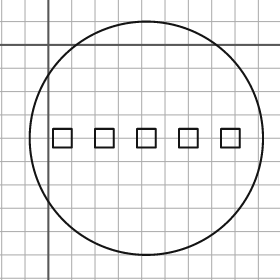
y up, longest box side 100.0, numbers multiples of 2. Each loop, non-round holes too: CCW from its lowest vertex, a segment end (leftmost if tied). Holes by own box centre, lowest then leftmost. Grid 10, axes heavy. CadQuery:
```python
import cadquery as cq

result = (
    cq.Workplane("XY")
    .moveTo(42.0, -40.0)
    .circle(50.0)
    .moveTo(2.0, -44.0)
    .lineTo(10.0, -44.0)
    .lineTo(10.0, -36.0)
    .lineTo(2.0, -36.0)
    .close()
    .moveTo(20.0, -44.0)
    .lineTo(28.0, -44.0)
    .lineTo(28.0, -36.0)
    .lineTo(20.0, -36.0)
    .close()
    .moveTo(38.0, -44.0)
    .lineTo(46.0, -44.0)
    .lineTo(46.0, -36.0)
    .lineTo(38.0, -36.0)
    .close()
    .moveTo(56.0, -44.0)
    .lineTo(64.0, -44.0)
    .lineTo(64.0, -36.0)
    .lineTo(56.0, -36.0)
    .close()
    .moveTo(74.0, -44.0)
    .lineTo(82.0, -44.0)
    .lineTo(82.0, -36.0)
    .lineTo(74.0, -36.0)
    .close()
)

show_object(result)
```